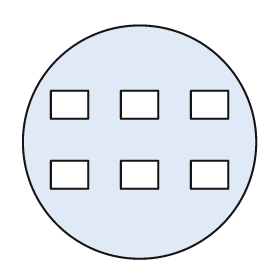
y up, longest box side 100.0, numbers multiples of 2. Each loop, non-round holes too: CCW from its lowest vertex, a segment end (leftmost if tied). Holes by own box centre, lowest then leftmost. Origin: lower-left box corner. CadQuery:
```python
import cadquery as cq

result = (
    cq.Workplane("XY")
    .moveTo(50.0, 50.0)
    .circle(50.0)
    .moveTo(12.0, 30.0)
    .lineTo(28.0, 30.0)
    .lineTo(28.0, 42.0)
    .lineTo(12.0, 42.0)
    .close()
    .moveTo(42.0, 30.0)
    .lineTo(58.0, 30.0)
    .lineTo(58.0, 42.0)
    .lineTo(42.0, 42.0)
    .close()
    .moveTo(72.0, 30.0)
    .lineTo(88.0, 30.0)
    .lineTo(88.0, 42.0)
    .lineTo(72.0, 42.0)
    .close()
    .moveTo(12.0, 60.0)
    .lineTo(28.0, 60.0)
    .lineTo(28.0, 72.0)
    .lineTo(12.0, 72.0)
    .close()
    .moveTo(42.0, 60.0)
    .lineTo(58.0, 60.0)
    .lineTo(58.0, 72.0)
    .lineTo(42.0, 72.0)
    .close()
    .moveTo(72.0, 60.0)
    .lineTo(88.0, 60.0)
    .lineTo(88.0, 72.0)
    .lineTo(72.0, 72.0)
    .close()
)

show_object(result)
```